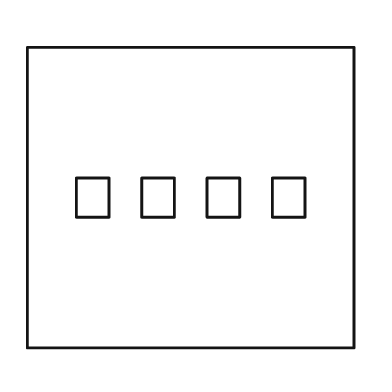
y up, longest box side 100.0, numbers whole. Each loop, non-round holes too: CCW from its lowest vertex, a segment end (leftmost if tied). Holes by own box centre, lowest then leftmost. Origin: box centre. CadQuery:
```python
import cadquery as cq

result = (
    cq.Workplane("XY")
    .moveTo(-50.0, -46.0)
    .lineTo(50.0, -46.0)
    .lineTo(50.0, 46.0)
    .lineTo(-50.0, 46.0)
    .close()
    .moveTo(-35.0, -6.0)
    .lineTo(-25.0, -6.0)
    .lineTo(-25.0, 6.0)
    .lineTo(-35.0, 6.0)
    .close()
    .moveTo(-15.0, -6.0)
    .lineTo(-5.0, -6.0)
    .lineTo(-5.0, 6.0)
    .lineTo(-15.0, 6.0)
    .close()
    .moveTo(5.0, -6.0)
    .lineTo(15.0, -6.0)
    .lineTo(15.0, 6.0)
    .lineTo(5.0, 6.0)
    .close()
    .moveTo(25.0, -6.0)
    .lineTo(35.0, -6.0)
    .lineTo(35.0, 6.0)
    .lineTo(25.0, 6.0)
    .close()
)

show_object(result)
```